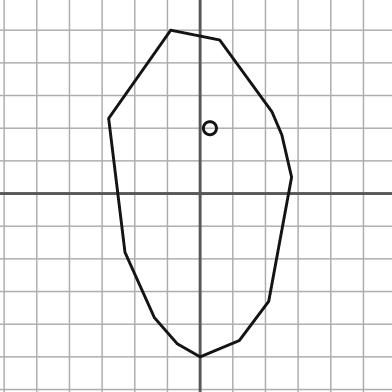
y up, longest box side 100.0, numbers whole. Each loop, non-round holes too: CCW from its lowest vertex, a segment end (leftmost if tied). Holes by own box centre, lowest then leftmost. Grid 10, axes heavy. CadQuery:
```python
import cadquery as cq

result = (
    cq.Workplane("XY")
    .moveTo(0.0, -50.0)
    .lineTo(12.0, -45.0)
    .lineTo(21.0, -33.0)
    .lineTo(28.0, 5.0)
    .lineTo(25.0, 18.0)
    .lineTo(22.0, 25.0)
    .lineTo(6.0, 47.0)
    .lineTo(-9.0, 50.0)
    .lineTo(-28.0, 23.0)
    .lineTo(-23.0, -18.0)
    .lineTo(-14.0, -38.0)
    .lineTo(-7.0, -46.0)
    .close()
    .moveTo(3.0, 20.0)
    .circle(2.0)
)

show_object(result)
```